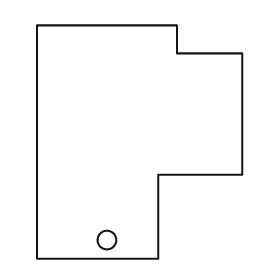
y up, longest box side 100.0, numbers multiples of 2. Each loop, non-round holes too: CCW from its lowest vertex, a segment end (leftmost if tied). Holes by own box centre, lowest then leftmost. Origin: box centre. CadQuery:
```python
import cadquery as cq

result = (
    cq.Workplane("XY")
    .moveTo(-44.0, -50.0)
    .lineTo(8.0, -50.0)
    .lineTo(8.0, -14.0)
    .lineTo(44.0, -14.0)
    .lineTo(44.0, 38.0)
    .lineTo(16.0, 38.0)
    .lineTo(16.0, 50.0)
    .lineTo(-44.0, 50.0)
    .close()
    .moveTo(-14.0, -42.0)
    .circle(4.0)
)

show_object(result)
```